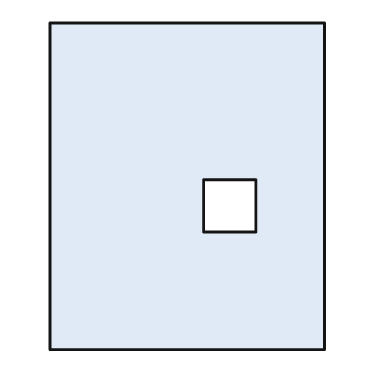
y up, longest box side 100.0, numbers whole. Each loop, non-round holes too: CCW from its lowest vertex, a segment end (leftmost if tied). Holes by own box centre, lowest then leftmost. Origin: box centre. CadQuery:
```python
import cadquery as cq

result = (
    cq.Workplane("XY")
    .moveTo(-42.0, -50.0)
    .lineTo(42.0, -50.0)
    .lineTo(42.0, 50.0)
    .lineTo(-42.0, 50.0)
    .close()
    .moveTo(5.0, -14.0)
    .lineTo(21.0, -14.0)
    .lineTo(21.0, 2.0)
    .lineTo(5.0, 2.0)
    .close()
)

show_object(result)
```